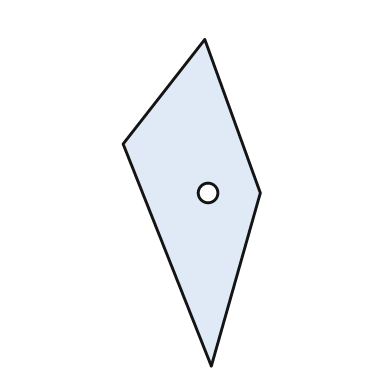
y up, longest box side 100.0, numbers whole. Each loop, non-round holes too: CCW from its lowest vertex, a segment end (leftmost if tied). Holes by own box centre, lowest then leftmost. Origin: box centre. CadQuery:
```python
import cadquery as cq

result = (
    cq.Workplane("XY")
    .moveTo(6.0, -50.0)
    .lineTo(21.0, 3.0)
    .lineTo(4.0, 50.0)
    .lineTo(-21.0, 18.0)
    .close()
    .moveTo(5.0, 3.0)
    .circle(3.0)
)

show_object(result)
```